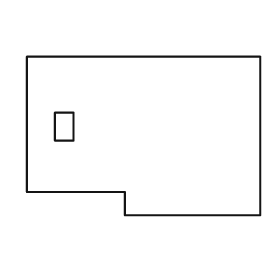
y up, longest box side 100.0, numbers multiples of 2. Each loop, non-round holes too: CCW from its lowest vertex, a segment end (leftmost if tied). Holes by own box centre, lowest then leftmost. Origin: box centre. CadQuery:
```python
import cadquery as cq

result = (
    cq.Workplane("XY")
    .moveTo(-8.0, -34.0)
    .lineTo(50.0, -34.0)
    .lineTo(50.0, 34.0)
    .lineTo(-50.0, 34.0)
    .lineTo(-50.0, -24.0)
    .lineTo(-8.0, -24.0)
    .close()
    .moveTo(-38.0, -2.0)
    .lineTo(-30.0, -2.0)
    .lineTo(-30.0, 10.0)
    .lineTo(-38.0, 10.0)
    .close()
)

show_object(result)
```